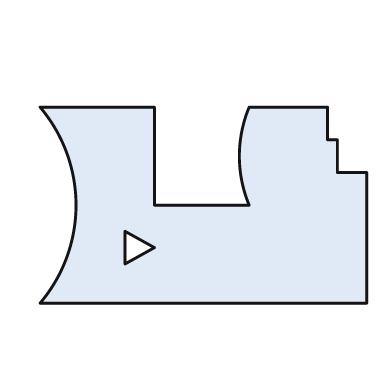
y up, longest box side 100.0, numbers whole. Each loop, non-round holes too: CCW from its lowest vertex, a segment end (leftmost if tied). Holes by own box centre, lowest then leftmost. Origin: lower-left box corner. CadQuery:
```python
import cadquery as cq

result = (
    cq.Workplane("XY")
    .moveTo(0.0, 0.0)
    .lineTo(100.0, 0.0)
    .lineTo(100.0, 40.0)
    .lineTo(91.0, 40.0)
    .lineTo(91.0, 50.0)
    .lineTo(88.0, 50.0)
    .lineTo(88.0, 60.0)
    .lineTo(64.0, 60.0)
    .threePointArc((61.0, 45.0), (64.0, 30.0))
    .lineTo(35.0, 30.0)
    .lineTo(35.0, 60.0)
    .lineTo(0.0, 60.0)
    .threePointArc((11.0, 30.0), (0.0, 0.0))
    .close()
    .moveTo(26.0, 12.0)
    .lineTo(35.0, 17.0)
    .lineTo(26.0, 22.0)
    .close()
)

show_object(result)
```